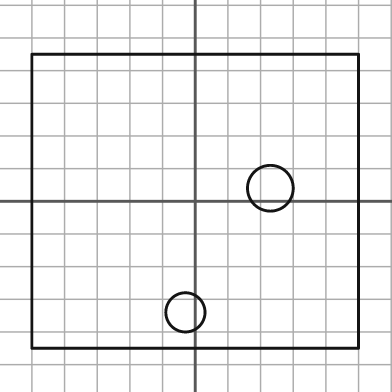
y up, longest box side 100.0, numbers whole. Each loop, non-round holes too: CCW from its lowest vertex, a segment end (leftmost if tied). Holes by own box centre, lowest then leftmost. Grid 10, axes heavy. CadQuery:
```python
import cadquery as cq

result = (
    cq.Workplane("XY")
    .moveTo(-50.0, -45.0)
    .lineTo(50.0, -45.0)
    .lineTo(50.0, 45.0)
    .lineTo(-50.0, 45.0)
    .close()
    .moveTo(-3.0, -34.0)
    .circle(6.0)
    .moveTo(23.0, 4.0)
    .circle(7.0)
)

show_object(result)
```